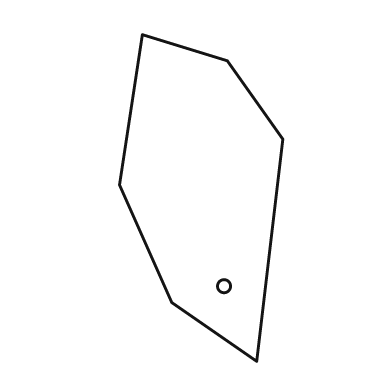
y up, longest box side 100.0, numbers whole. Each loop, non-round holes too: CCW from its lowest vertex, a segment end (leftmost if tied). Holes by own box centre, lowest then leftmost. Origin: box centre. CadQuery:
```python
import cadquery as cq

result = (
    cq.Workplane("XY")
    .moveTo(17.0, -50.0)
    .lineTo(25.0, 18.0)
    .lineTo(8.0, 42.0)
    .lineTo(-18.0, 50.0)
    .lineTo(-25.0, 4.0)
    .lineTo(-9.0, -32.0)
    .close()
    .moveTo(7.0, -27.0)
    .circle(2.0)
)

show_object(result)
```